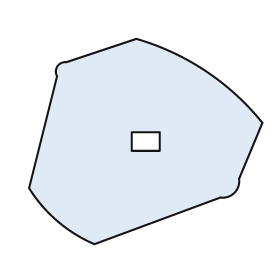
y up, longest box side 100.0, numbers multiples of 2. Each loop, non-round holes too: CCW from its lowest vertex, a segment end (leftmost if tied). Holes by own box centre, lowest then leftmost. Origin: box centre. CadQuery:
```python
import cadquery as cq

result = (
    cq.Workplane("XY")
    .moveTo(-22.0, -44.0)
    .lineTo(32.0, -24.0)
    .threePointArc((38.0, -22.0), (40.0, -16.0))
    .lineTo(50.0, 8.0)
    .threePointArc((26.0, 30.0), (-4.0, 44.0))
    .lineTo(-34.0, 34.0)
    .threePointArc((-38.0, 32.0), (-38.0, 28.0))
    .lineTo(-50.0, -20.0)
    .threePointArc((-38.0, -34.0), (-22.0, -44.0))
    .close()
    .moveTo(-6.0, -4.0)
    .lineTo(6.0, -4.0)
    .lineTo(6.0, 4.0)
    .lineTo(-6.0, 4.0)
    .close()
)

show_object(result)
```